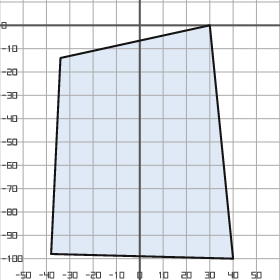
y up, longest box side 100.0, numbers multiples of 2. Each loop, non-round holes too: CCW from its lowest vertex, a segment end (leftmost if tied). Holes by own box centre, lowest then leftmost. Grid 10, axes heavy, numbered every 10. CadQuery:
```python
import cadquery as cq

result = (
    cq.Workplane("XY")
    .moveTo(40.0, -100.0)
    .lineTo(30.0, 0.0)
    .lineTo(-34.0, -14.0)
    .lineTo(-38.0, -98.0)
    .close()
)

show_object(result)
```